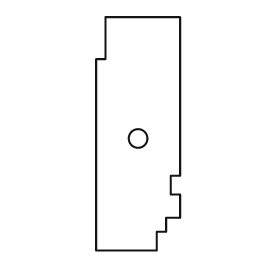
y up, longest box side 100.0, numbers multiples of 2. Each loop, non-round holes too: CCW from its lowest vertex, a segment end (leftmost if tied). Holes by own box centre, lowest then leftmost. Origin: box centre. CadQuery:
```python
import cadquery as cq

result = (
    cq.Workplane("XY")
    .moveTo(-18.0, -50.0)
    .lineTo(8.0, -50.0)
    .lineTo(8.0, -42.0)
    .lineTo(12.0, -42.0)
    .lineTo(12.0, -36.0)
    .lineTo(18.0, -36.0)
    .lineTo(18.0, -26.0)
    .lineTo(14.0, -26.0)
    .lineTo(14.0, -18.0)
    .lineTo(18.0, -18.0)
    .lineTo(18.0, 50.0)
    .lineTo(-14.0, 50.0)
    .lineTo(-14.0, 32.0)
    .lineTo(-18.0, 32.0)
    .close()
    .moveTo(0.0, -2.0)
    .circle(4.0)
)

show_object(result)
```